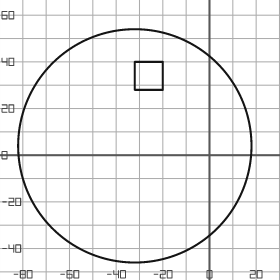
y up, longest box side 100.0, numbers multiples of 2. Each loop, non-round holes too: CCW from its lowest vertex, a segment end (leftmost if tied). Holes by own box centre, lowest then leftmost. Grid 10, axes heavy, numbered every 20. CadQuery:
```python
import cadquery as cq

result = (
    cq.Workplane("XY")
    .moveTo(-32.0, 4.0)
    .circle(50.0)
    .moveTo(-32.0, 28.0)
    .lineTo(-20.0, 28.0)
    .lineTo(-20.0, 40.0)
    .lineTo(-32.0, 40.0)
    .close()
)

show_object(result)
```